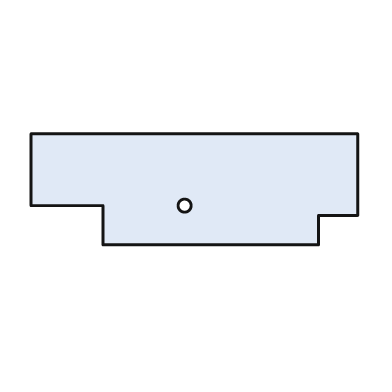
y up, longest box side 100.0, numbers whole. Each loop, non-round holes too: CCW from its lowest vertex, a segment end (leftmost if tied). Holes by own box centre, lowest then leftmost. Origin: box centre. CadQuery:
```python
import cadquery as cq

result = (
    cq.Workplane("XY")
    .moveTo(-28.0, -17.0)
    .lineTo(38.0, -17.0)
    .lineTo(38.0, -8.0)
    .lineTo(50.0, -8.0)
    .lineTo(50.0, 17.0)
    .lineTo(-50.0, 17.0)
    .lineTo(-50.0, -5.0)
    .lineTo(-28.0, -5.0)
    .close()
    .moveTo(-3.0, -5.0)
    .circle(2.0)
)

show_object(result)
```